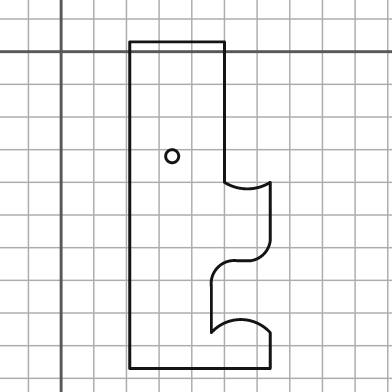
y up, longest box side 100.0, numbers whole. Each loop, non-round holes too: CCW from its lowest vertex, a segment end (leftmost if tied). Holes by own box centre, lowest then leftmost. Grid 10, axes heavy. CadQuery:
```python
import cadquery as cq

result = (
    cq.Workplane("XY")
    .moveTo(21.0, -97.0)
    .lineTo(64.0, -97.0)
    .lineTo(64.0, -86.0)
    .threePointArc((55.0, -82.0), (46.0, -86.0))
    .lineTo(46.0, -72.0)
    .threePointArc((48.0, -66.0), (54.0, -64.0))
    .lineTo(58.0, -64.0)
    .threePointArc((62.0, -62.0), (64.0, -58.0))
    .lineTo(64.0, -40.0)
    .threePointArc((57.0, -42.0), (50.0, -40.0))
    .lineTo(50.0, 3.0)
    .lineTo(21.0, 3.0)
    .close()
    .moveTo(34.0, -32.0)
    .circle(2.0)
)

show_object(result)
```